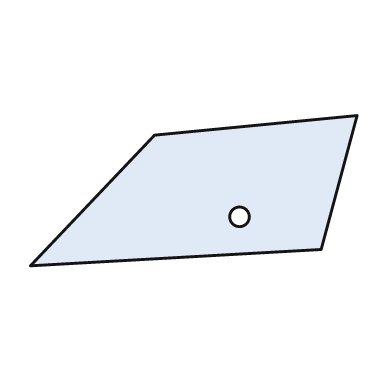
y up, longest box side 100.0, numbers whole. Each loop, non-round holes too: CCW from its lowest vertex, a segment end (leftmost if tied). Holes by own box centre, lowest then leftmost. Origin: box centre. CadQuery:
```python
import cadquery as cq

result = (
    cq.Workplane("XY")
    .moveTo(-50.0, -23.0)
    .lineTo(39.0, -18.0)
    .lineTo(50.0, 23.0)
    .lineTo(-12.0, 17.0)
    .close()
    .moveTo(14.0, -8.0)
    .circle(3.0)
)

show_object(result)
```